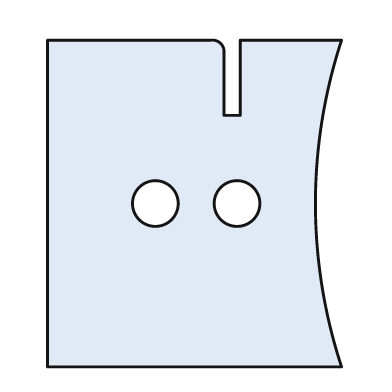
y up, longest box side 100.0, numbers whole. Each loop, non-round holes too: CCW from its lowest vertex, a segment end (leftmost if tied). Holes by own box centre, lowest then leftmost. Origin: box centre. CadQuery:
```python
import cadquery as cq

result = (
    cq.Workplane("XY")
    .moveTo(-45.0, -50.0)
    .lineTo(45.0, -50.0)
    .threePointArc((37.0, 0.0), (45.0, 50.0))
    .lineTo(14.0, 50.0)
    .lineTo(14.0, 27.0)
    .lineTo(9.0, 27.0)
    .lineTo(9.0, 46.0)
    .threePointArc((8.0, 49.0), (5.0, 50.0))
    .lineTo(-45.0, 50.0)
    .close()
    .moveTo(-12.0, 0.0)
    .circle(7.0)
    .moveTo(13.0, 0.0)
    .circle(7.0)
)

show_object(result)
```